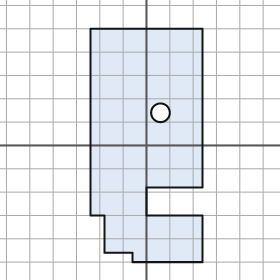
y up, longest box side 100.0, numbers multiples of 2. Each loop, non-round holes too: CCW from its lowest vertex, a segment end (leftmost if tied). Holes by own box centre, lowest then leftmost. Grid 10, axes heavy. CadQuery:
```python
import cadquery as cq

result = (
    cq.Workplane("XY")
    .moveTo(-6.0, -50.0)
    .lineTo(24.0, -50.0)
    .lineTo(24.0, -30.0)
    .lineTo(0.0, -30.0)
    .lineTo(0.0, -18.0)
    .lineTo(24.0, -18.0)
    .lineTo(24.0, 50.0)
    .lineTo(-24.0, 50.0)
    .lineTo(-24.0, -30.0)
    .lineTo(-18.0, -30.0)
    .lineTo(-18.0, -46.0)
    .lineTo(-6.0, -46.0)
    .close()
    .moveTo(6.0, 14.0)
    .circle(4.0)
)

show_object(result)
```